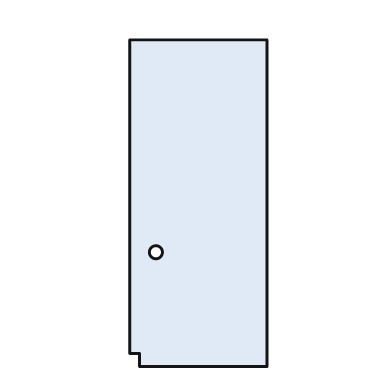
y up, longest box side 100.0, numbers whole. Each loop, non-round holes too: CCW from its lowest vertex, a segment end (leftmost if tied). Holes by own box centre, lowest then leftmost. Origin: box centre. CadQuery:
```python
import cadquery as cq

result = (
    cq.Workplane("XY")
    .moveTo(-18.0, -50.0)
    .lineTo(21.0, -50.0)
    .lineTo(21.0, 50.0)
    .lineTo(-21.0, 50.0)
    .lineTo(-21.0, -46.0)
    .lineTo(-18.0, -46.0)
    .close()
    .moveTo(-13.0, -15.0)
    .circle(2.0)
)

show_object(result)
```